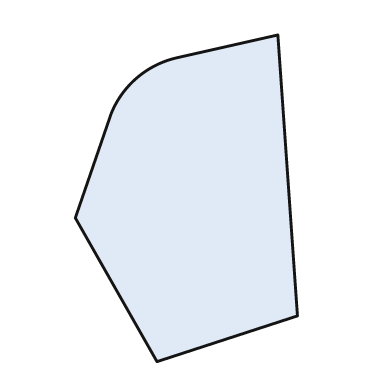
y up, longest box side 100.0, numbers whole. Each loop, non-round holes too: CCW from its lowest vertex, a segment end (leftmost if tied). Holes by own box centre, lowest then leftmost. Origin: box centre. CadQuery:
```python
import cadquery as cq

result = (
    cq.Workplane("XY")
    .moveTo(-9.0, -50.0)
    .lineTo(34.0, -36.0)
    .lineTo(28.0, 50.0)
    .lineTo(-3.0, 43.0)
    .threePointArc((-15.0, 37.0), (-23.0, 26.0))
    .lineTo(-34.0, -6.0)
    .close()
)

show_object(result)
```